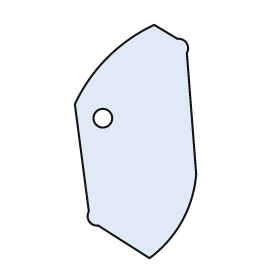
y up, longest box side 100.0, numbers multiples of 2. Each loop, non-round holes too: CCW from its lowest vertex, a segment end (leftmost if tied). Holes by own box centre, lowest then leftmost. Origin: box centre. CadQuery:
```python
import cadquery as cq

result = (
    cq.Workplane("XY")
    .moveTo(6.0, -50.0)
    .threePointArc((20.0, -34.0), (26.0, -14.0))
    .lineTo(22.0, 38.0)
    .threePointArc((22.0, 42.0), (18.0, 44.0))
    .lineTo(8.0, 50.0)
    .threePointArc((-12.0, 36.0), (-26.0, 16.0))
    .lineTo(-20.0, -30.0)
    .threePointArc((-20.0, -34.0), (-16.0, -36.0))
    .close()
    .moveTo(-14.0, 10.0)
    .circle(4.0)
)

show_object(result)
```